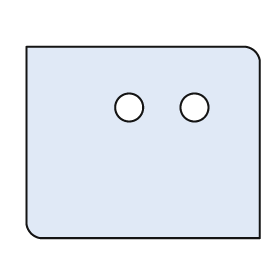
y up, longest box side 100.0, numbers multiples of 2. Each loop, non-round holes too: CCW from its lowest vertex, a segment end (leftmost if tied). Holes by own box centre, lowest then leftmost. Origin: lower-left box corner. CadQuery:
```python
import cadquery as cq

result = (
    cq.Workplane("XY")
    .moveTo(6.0, 0.0)
    .lineTo(100.0, 0.0)
    .lineTo(100.0, 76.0)
    .threePointArc((98.0, 80.0), (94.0, 82.0))
    .lineTo(0.0, 82.0)
    .lineTo(0.0, 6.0)
    .threePointArc((2.0, 2.0), (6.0, 0.0))
    .close()
    .moveTo(44.0, 56.0)
    .circle(6.0)
    .moveTo(72.0, 56.0)
    .circle(6.0)
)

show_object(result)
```